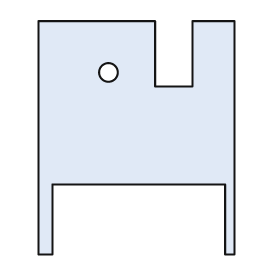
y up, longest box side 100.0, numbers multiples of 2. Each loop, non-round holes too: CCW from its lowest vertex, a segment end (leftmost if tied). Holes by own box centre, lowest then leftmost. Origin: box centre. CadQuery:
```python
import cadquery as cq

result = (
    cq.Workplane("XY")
    .moveTo(-42.0, -50.0)
    .lineTo(-36.0, -50.0)
    .lineTo(-36.0, -20.0)
    .lineTo(38.0, -20.0)
    .lineTo(38.0, -50.0)
    .lineTo(42.0, -50.0)
    .lineTo(42.0, 50.0)
    .lineTo(24.0, 50.0)
    .lineTo(24.0, 22.0)
    .lineTo(8.0, 22.0)
    .lineTo(8.0, 50.0)
    .lineTo(-42.0, 50.0)
    .close()
    .moveTo(-12.0, 28.0)
    .circle(4.0)
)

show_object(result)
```